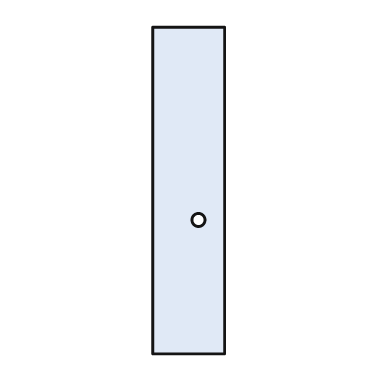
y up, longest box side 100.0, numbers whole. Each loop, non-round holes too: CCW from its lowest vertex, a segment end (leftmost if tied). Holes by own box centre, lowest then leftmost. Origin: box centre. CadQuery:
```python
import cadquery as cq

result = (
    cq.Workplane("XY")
    .moveTo(-11.0, -50.0)
    .lineTo(11.0, -50.0)
    .lineTo(11.0, 50.0)
    .lineTo(-11.0, 50.0)
    .close()
    .moveTo(3.0, -9.0)
    .circle(2.0)
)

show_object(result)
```